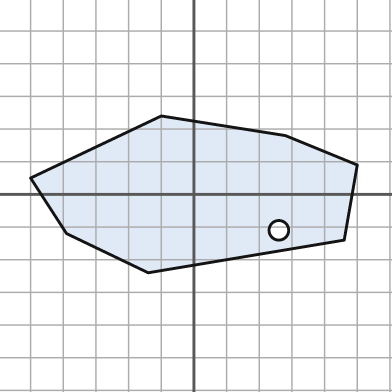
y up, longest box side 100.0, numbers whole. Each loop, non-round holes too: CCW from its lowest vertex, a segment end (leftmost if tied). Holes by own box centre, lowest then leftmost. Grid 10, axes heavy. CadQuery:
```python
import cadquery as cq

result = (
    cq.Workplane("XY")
    .moveTo(-14.0, -24.0)
    .lineTo(46.0, -14.0)
    .lineTo(50.0, 9.0)
    .lineTo(28.0, 18.0)
    .lineTo(-10.0, 24.0)
    .lineTo(-50.0, 5.0)
    .lineTo(-39.0, -12.0)
    .close()
    .moveTo(26.0, -11.0)
    .circle(3.0)
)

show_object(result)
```